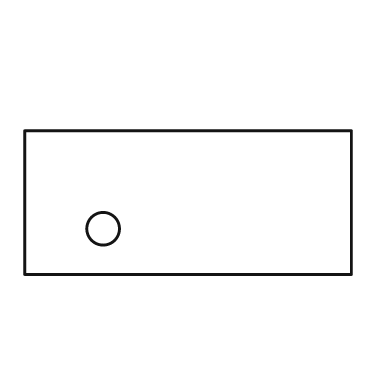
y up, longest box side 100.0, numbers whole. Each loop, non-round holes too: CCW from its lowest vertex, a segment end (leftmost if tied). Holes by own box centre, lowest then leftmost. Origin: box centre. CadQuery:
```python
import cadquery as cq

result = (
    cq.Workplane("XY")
    .moveTo(-50.0, -22.0)
    .lineTo(50.0, -22.0)
    .lineTo(50.0, 22.0)
    .lineTo(-50.0, 22.0)
    .close()
    .moveTo(-26.0, -8.0)
    .circle(5.0)
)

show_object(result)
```